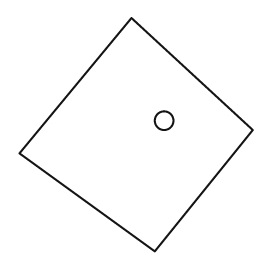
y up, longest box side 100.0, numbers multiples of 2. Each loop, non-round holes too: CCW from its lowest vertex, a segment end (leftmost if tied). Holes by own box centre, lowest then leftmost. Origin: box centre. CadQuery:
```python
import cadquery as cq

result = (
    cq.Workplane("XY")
    .moveTo(8.0, -50.0)
    .lineTo(50.0, 2.0)
    .lineTo(-2.0, 50.0)
    .lineTo(-50.0, -8.0)
    .close()
    .moveTo(12.0, 6.0)
    .circle(4.0)
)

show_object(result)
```